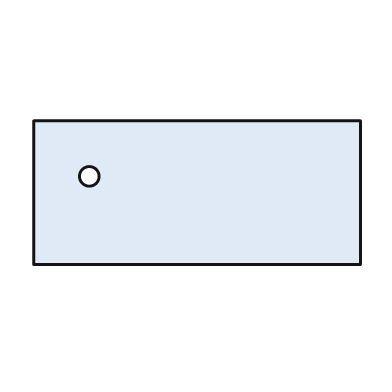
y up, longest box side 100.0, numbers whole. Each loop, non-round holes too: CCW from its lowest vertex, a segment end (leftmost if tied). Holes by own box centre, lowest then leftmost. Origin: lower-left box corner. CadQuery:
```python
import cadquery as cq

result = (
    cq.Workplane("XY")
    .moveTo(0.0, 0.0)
    .lineTo(100.0, 0.0)
    .lineTo(100.0, 44.0)
    .lineTo(0.0, 44.0)
    .close()
    .moveTo(17.0, 27.0)
    .circle(3.0)
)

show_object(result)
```